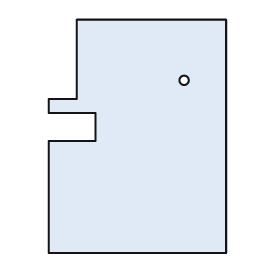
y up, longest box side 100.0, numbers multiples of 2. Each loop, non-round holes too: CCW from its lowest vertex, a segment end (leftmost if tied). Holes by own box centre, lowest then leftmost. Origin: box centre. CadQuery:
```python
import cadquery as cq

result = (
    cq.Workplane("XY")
    .moveTo(-38.0, -50.0)
    .lineTo(38.0, -50.0)
    .lineTo(38.0, 50.0)
    .lineTo(-26.0, 50.0)
    .lineTo(-26.0, 16.0)
    .lineTo(-38.0, 16.0)
    .lineTo(-38.0, 10.0)
    .lineTo(-18.0, 10.0)
    .lineTo(-18.0, -2.0)
    .lineTo(-38.0, -2.0)
    .close()
    .moveTo(20.0, 24.0)
    .circle(2.0)
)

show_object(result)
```